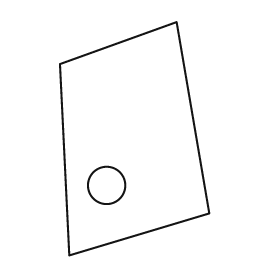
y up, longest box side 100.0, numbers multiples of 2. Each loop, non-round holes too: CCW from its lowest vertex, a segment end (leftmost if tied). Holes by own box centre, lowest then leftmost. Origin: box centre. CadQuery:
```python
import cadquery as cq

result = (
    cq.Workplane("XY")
    .moveTo(-28.0, -50.0)
    .lineTo(32.0, -32.0)
    .lineTo(18.0, 50.0)
    .lineTo(-32.0, 32.0)
    .close()
    .moveTo(-12.0, -20.0)
    .circle(8.0)
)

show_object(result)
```